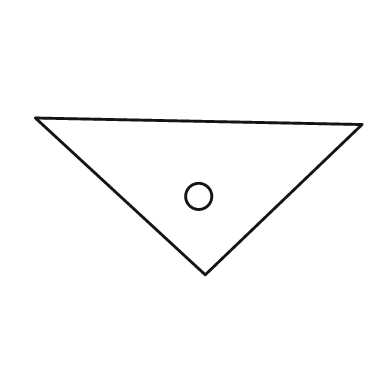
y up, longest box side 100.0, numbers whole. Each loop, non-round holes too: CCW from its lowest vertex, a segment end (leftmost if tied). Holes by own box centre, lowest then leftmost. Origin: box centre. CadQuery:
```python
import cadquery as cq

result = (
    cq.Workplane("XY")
    .moveTo(2.0, -24.0)
    .lineTo(50.0, 22.0)
    .lineTo(-50.0, 24.0)
    .close()
    .moveTo(0.0, 0.0)
    .circle(4.0)
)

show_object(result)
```